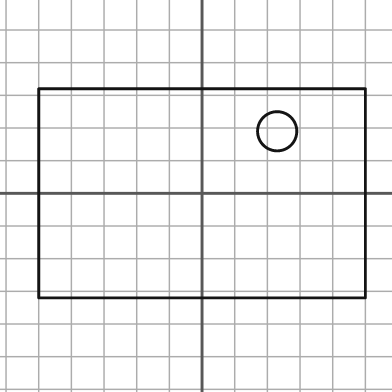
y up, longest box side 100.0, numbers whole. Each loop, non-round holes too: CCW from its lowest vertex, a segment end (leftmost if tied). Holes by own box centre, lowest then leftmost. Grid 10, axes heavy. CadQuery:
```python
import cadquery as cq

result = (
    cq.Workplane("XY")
    .moveTo(-50.0, -32.0)
    .lineTo(50.0, -32.0)
    .lineTo(50.0, 32.0)
    .lineTo(-50.0, 32.0)
    .close()
    .moveTo(23.0, 19.0)
    .circle(6.0)
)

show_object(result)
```